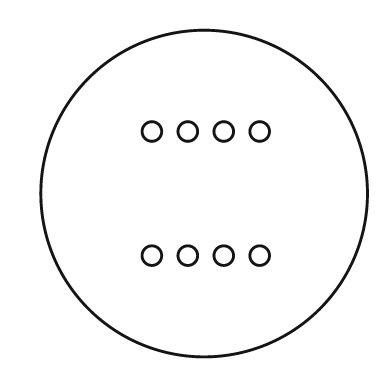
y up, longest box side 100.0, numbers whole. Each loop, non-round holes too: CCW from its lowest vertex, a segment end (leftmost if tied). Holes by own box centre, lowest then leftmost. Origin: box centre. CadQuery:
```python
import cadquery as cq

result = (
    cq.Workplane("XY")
    .moveTo(0.0, 0.0)
    .circle(50.0)
    .moveTo(-16.0, -19.0)
    .circle(3.0)
    .moveTo(-5.0, -19.0)
    .circle(3.0)
    .moveTo(6.0, -19.0)
    .circle(3.0)
    .moveTo(17.0, -19.0)
    .circle(3.0)
    .moveTo(-16.0, 19.0)
    .circle(3.0)
    .moveTo(-5.0, 19.0)
    .circle(3.0)
    .moveTo(6.0, 19.0)
    .circle(3.0)
    .moveTo(17.0, 19.0)
    .circle(3.0)
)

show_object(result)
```